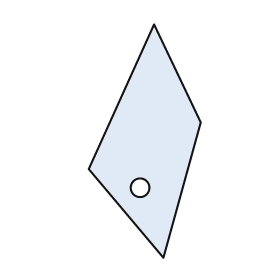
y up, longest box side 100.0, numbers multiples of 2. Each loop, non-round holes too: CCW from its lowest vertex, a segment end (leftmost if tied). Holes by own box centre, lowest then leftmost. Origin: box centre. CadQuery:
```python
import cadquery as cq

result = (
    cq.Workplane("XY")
    .moveTo(8.0, -50.0)
    .lineTo(24.0, 8.0)
    .lineTo(4.0, 50.0)
    .lineTo(-24.0, -12.0)
    .close()
    .moveTo(-2.0, -20.0)
    .circle(4.0)
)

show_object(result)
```